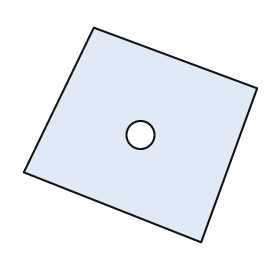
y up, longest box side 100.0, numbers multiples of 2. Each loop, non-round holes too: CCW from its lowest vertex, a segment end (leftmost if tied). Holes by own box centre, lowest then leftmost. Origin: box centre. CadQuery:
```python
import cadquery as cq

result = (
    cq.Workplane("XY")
    .moveTo(26.0, -46.0)
    .lineTo(50.0, 20.0)
    .lineTo(-20.0, 46.0)
    .lineTo(-50.0, -16.0)
    .close()
    .moveTo(0.0, 0.0)
    .circle(6.0)
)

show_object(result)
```